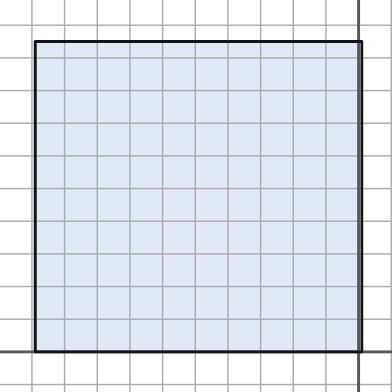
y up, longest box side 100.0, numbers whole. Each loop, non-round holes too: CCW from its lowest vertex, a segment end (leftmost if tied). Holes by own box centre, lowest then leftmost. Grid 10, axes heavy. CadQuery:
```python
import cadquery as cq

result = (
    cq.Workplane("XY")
    .moveTo(-99.0, 0.0)
    .lineTo(1.0, 0.0)
    .lineTo(1.0, 95.0)
    .lineTo(-99.0, 95.0)
    .close()
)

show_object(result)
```